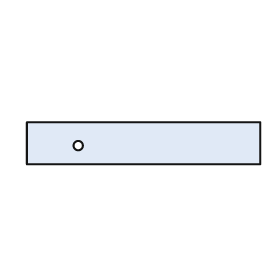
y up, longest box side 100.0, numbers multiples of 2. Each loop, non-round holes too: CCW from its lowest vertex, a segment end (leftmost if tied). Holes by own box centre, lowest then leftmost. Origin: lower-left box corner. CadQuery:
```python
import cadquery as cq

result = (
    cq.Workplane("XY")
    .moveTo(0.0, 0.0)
    .lineTo(100.0, 0.0)
    .lineTo(100.0, 18.0)
    .lineTo(0.0, 18.0)
    .close()
    .moveTo(22.0, 8.0)
    .circle(2.0)
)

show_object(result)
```